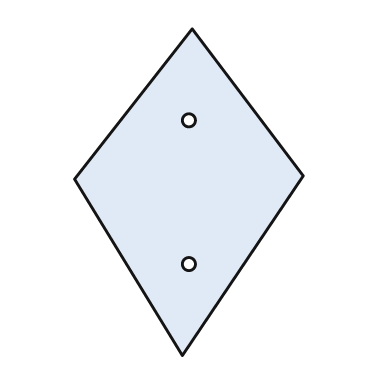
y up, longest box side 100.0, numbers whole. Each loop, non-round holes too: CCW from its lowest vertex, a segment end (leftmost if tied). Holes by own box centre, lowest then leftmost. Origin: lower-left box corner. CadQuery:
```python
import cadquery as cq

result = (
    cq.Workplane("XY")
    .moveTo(33.0, 0.0)
    .lineTo(70.0, 55.0)
    .lineTo(36.0, 100.0)
    .lineTo(0.0, 54.0)
    .close()
    .moveTo(35.0, 28.0)
    .circle(2.0)
    .moveTo(35.0, 72.0)
    .circle(2.0)
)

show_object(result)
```